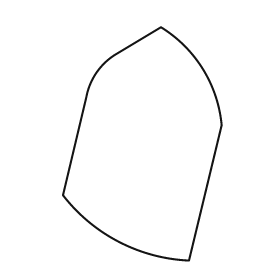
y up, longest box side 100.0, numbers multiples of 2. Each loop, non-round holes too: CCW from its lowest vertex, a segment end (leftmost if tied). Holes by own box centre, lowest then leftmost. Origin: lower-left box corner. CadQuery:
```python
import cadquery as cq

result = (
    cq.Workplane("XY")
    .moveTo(54.0, 0.0)
    .lineTo(68.0, 58.0)
    .threePointArc((60.0, 82.0), (42.0, 100.0))
    .lineTo(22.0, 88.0)
    .threePointArc((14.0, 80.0), (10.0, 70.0))
    .lineTo(0.0, 28.0)
    .threePointArc((24.0, 8.0), (54.0, 0.0))
    .close()
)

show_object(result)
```